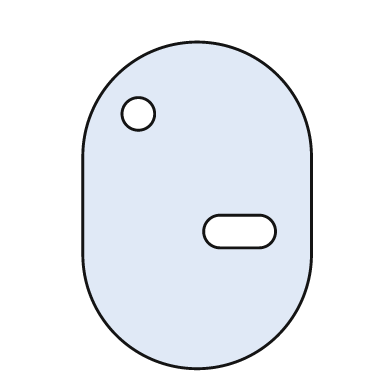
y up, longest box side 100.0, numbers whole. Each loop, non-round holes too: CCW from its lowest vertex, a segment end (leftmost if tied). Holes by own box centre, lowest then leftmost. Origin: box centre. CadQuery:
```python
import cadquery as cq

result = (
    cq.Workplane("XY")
    .moveTo(-35.0, -15.0)
    .threePointArc((0.0, -50.0), (35.0, -15.0))
    .lineTo(35.0, 15.0)
    .threePointArc((0.0, 50.0), (-35.0, 15.0))
    .close()
    .moveTo(7.0, -13.0)
    .lineTo(19.0, -13.0)
    .threePointArc((24.0, -8.0), (19.0, -3.0))
    .lineTo(7.0, -3.0)
    .threePointArc((2.0, -8.0), (7.0, -13.0))
    .close()
    .moveTo(-18.0, 28.0)
    .circle(5.0)
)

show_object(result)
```